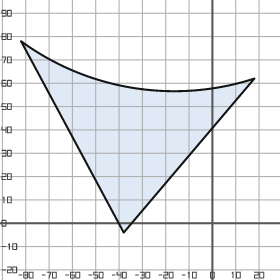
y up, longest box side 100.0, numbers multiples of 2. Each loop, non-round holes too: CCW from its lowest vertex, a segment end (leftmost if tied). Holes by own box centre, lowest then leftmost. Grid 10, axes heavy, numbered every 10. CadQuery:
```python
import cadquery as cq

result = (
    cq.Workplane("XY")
    .moveTo(-38.0, -4.0)
    .lineTo(18.0, 62.0)
    .threePointArc((-34.0, 58.0), (-82.0, 78.0))
    .close()
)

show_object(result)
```